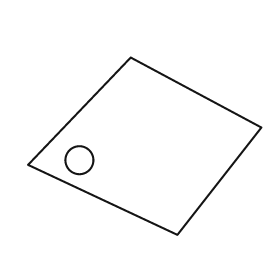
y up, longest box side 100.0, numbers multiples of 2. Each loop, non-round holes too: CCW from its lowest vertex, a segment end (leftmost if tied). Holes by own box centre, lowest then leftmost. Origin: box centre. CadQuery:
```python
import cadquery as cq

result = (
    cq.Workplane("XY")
    .moveTo(14.0, -38.0)
    .lineTo(50.0, 8.0)
    .lineTo(-6.0, 38.0)
    .lineTo(-50.0, -8.0)
    .close()
    .moveTo(-28.0, -6.0)
    .circle(6.0)
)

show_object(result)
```